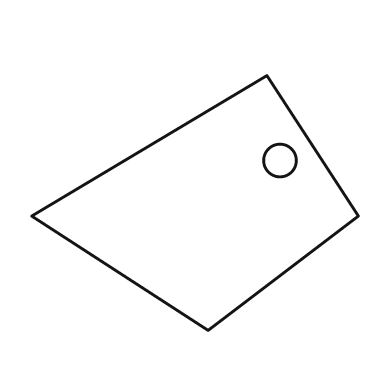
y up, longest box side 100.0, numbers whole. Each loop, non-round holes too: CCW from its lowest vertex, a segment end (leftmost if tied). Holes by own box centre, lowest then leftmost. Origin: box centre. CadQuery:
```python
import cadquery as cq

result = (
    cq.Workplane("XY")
    .moveTo(4.0, -39.0)
    .lineTo(50.0, -4.0)
    .lineTo(22.0, 39.0)
    .lineTo(-50.0, -4.0)
    .close()
    .moveTo(26.0, 13.0)
    .circle(5.0)
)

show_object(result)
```